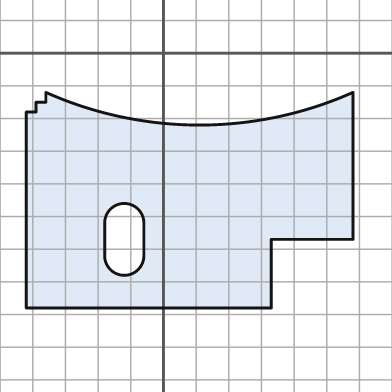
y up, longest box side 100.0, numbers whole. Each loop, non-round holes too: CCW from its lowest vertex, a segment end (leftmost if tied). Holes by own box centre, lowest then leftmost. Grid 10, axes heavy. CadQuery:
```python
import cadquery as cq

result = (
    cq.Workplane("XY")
    .moveTo(-42.0, -78.0)
    .lineTo(33.0, -78.0)
    .lineTo(33.0, -57.0)
    .lineTo(58.0, -57.0)
    .lineTo(58.0, -12.0)
    .threePointArc((11.0, -22.0), (-36.0, -12.0))
    .lineTo(-36.0, -15.0)
    .lineTo(-39.0, -15.0)
    .lineTo(-39.0, -18.0)
    .lineTo(-42.0, -18.0)
    .close()
    .moveTo(-18.0, -62.0)
    .threePointArc((-12.0, -68.0), (-6.0, -62.0))
    .lineTo(-6.0, -52.0)
    .threePointArc((-12.0, -46.0), (-18.0, -52.0))
    .close()
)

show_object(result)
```